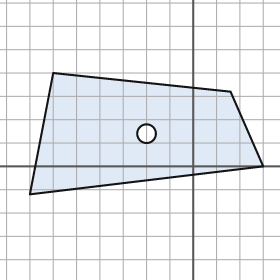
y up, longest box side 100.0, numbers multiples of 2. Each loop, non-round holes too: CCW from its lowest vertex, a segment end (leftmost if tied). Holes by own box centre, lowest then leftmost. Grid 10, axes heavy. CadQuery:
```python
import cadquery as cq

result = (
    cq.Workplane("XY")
    .moveTo(-70.0, -12.0)
    .lineTo(30.0, 0.0)
    .lineTo(16.0, 32.0)
    .lineTo(-60.0, 40.0)
    .close()
    .moveTo(-20.0, 14.0)
    .circle(4.0)
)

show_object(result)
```